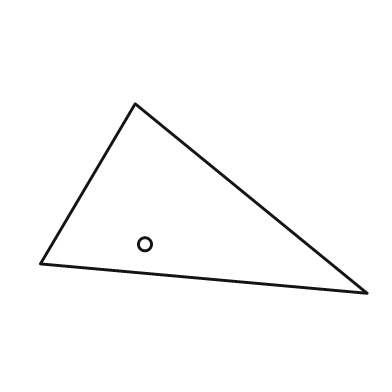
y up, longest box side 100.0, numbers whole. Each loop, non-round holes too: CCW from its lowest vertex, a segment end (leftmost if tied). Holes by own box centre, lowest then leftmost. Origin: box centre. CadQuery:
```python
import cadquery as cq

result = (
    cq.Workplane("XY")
    .moveTo(50.0, -29.0)
    .lineTo(-21.0, 29.0)
    .lineTo(-50.0, -20.0)
    .close()
    .moveTo(-18.0, -14.0)
    .circle(2.0)
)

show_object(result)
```